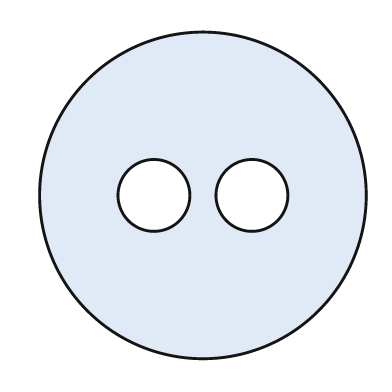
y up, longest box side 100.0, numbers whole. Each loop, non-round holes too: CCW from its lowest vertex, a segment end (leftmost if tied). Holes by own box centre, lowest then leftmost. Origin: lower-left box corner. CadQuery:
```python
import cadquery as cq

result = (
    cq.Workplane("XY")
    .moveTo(50.0, 50.0)
    .circle(50.0)
    .moveTo(35.0, 50.0)
    .circle(11.0)
    .moveTo(65.0, 50.0)
    .circle(11.0)
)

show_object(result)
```